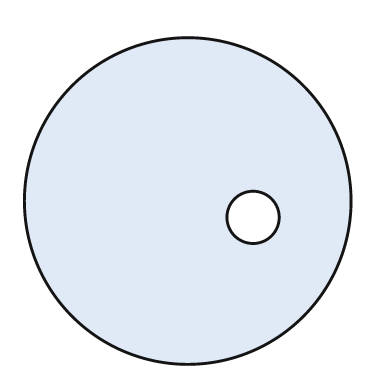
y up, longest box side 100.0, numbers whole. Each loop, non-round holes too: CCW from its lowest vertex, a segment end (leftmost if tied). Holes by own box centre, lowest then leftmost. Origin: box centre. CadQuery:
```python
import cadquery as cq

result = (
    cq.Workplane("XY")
    .moveTo(0.0, 0.0)
    .circle(50.0)
    .moveTo(20.0, -5.0)
    .circle(8.0)
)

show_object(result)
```